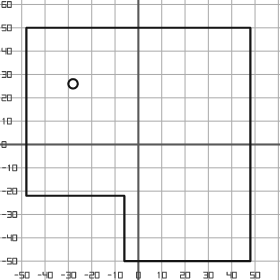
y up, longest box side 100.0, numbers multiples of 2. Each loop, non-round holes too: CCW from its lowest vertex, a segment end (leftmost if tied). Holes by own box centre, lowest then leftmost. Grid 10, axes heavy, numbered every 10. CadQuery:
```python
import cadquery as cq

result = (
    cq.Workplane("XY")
    .moveTo(-6.0, -50.0)
    .lineTo(48.0, -50.0)
    .lineTo(48.0, 50.0)
    .lineTo(-48.0, 50.0)
    .lineTo(-48.0, -22.0)
    .lineTo(-6.0, -22.0)
    .close()
    .moveTo(-28.0, 26.0)
    .circle(2.0)
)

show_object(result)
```